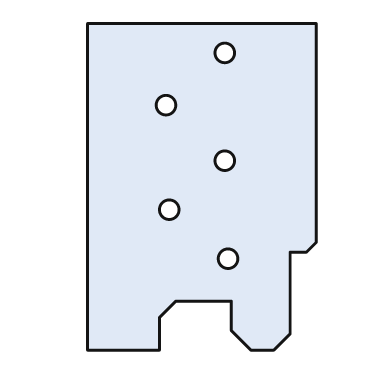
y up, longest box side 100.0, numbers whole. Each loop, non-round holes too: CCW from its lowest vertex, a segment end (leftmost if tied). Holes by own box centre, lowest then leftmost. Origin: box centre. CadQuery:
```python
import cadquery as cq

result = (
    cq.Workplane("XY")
    .moveTo(-35.0, -50.0)
    .lineTo(-13.0, -50.0)
    .lineTo(-13.0, -40.0)
    .lineTo(-8.0, -35.0)
    .lineTo(9.0, -35.0)
    .lineTo(9.0, -44.0)
    .lineTo(15.0, -50.0)
    .lineTo(22.0, -50.0)
    .lineTo(27.0, -45.0)
    .lineTo(27.0, -20.0)
    .lineTo(32.0, -20.0)
    .lineTo(35.0, -17.0)
    .lineTo(35.0, 50.0)
    .lineTo(-35.0, 50.0)
    .close()
    .moveTo(8.0, -22.0)
    .circle(3.0)
    .moveTo(-10.0, -7.0)
    .circle(3.0)
    .moveTo(7.0, 8.0)
    .circle(3.0)
    .moveTo(-11.0, 25.0)
    .circle(3.0)
    .moveTo(7.0, 41.0)
    .circle(3.0)
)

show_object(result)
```